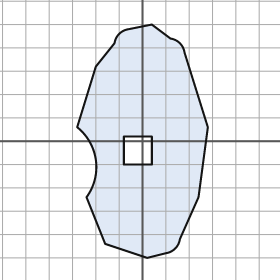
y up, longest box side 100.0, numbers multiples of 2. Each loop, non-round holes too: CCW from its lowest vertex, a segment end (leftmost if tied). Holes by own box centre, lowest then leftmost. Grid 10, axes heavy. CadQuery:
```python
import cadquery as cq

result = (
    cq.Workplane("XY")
    .moveTo(2.0, -50.0)
    .lineTo(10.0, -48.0)
    .threePointArc((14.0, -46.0), (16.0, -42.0))
    .lineTo(24.0, -24.0)
    .lineTo(28.0, 6.0)
    .lineTo(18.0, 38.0)
    .threePointArc((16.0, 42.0), (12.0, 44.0))
    .lineTo(4.0, 50.0)
    .lineTo(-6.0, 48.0)
    .threePointArc((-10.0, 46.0), (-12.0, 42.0))
    .lineTo(-20.0, 32.0)
    .lineTo(-28.0, 6.0)
    .threePointArc((-20.0, -8.0), (-24.0, -24.0))
    .lineTo(-16.0, -44.0)
    .close()
    .moveTo(-8.0, -10.0)
    .lineTo(4.0, -10.0)
    .lineTo(4.0, 2.0)
    .lineTo(-8.0, 2.0)
    .close()
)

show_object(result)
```